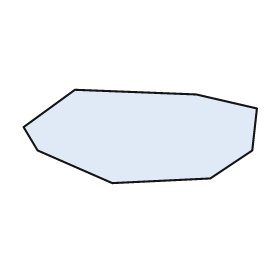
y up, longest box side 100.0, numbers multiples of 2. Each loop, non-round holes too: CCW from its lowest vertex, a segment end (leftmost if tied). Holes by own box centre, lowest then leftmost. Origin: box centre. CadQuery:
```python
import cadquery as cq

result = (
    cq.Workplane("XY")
    .moveTo(-12.0, -20.0)
    .lineTo(30.0, -18.0)
    .lineTo(48.0, -6.0)
    .lineTo(50.0, 12.0)
    .lineTo(24.0, 18.0)
    .lineTo(-28.0, 20.0)
    .lineTo(-50.0, 4.0)
    .lineTo(-44.0, -6.0)
    .close()
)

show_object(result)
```